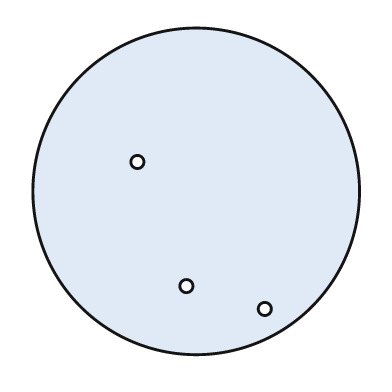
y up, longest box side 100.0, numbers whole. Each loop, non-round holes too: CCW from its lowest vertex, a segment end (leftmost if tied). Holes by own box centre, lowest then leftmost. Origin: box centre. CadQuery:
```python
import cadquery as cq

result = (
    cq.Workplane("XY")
    .moveTo(0.0, 0.0)
    .circle(50.0)
    .moveTo(21.0, -36.0)
    .circle(2.0)
    .moveTo(-3.0, -29.0)
    .circle(2.0)
    .moveTo(-18.0, 9.0)
    .circle(2.0)
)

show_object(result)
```